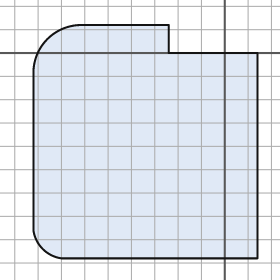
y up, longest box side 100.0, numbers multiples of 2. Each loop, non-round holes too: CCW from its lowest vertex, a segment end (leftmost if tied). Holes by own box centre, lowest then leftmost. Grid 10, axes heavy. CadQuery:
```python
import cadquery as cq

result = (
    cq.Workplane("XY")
    .moveTo(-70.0, -88.0)
    .lineTo(14.0, -88.0)
    .lineTo(14.0, 0.0)
    .lineTo(-24.0, 0.0)
    .lineTo(-24.0, 12.0)
    .lineTo(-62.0, 12.0)
    .threePointArc((-76.0, 6.0), (-82.0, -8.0))
    .lineTo(-82.0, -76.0)
    .threePointArc((-78.0, -84.0), (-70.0, -88.0))
    .close()
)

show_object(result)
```